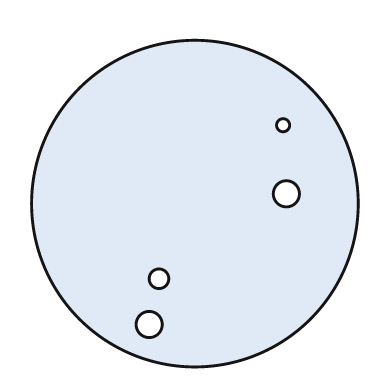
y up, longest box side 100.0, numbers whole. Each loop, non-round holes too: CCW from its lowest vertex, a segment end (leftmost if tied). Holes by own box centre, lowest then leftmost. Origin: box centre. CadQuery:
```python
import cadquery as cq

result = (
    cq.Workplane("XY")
    .moveTo(0.0, 0.0)
    .circle(50.0)
    .moveTo(-14.0, -37.0)
    .circle(4.0)
    .moveTo(-11.0, -23.0)
    .circle(3.0)
    .moveTo(28.0, 3.0)
    .circle(4.0)
    .moveTo(27.0, 24.0)
    .circle(2.0)
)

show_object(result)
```